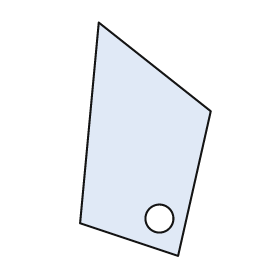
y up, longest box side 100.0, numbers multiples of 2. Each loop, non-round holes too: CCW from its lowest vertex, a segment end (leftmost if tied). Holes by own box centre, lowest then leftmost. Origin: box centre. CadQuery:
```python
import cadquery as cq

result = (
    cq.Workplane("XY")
    .moveTo(14.0, -50.0)
    .lineTo(28.0, 12.0)
    .lineTo(-20.0, 50.0)
    .lineTo(-28.0, -36.0)
    .close()
    .moveTo(6.0, -34.0)
    .circle(6.0)
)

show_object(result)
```